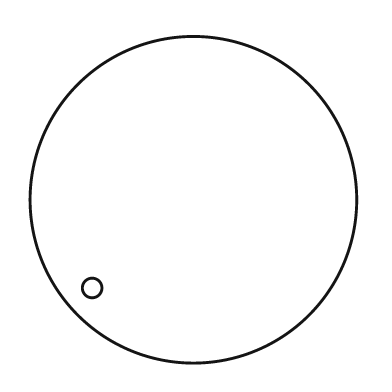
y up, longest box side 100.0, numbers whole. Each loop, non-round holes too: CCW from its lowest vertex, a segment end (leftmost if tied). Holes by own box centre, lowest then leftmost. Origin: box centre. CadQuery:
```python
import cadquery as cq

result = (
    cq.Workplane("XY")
    .moveTo(0.0, 0.0)
    .circle(50.0)
    .moveTo(-31.0, -27.0)
    .circle(3.0)
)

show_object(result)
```